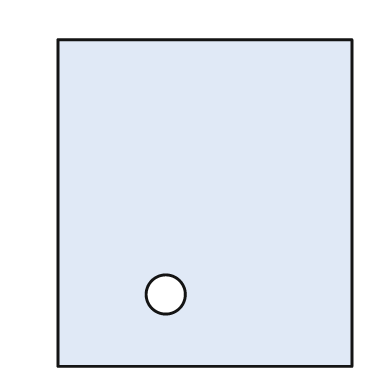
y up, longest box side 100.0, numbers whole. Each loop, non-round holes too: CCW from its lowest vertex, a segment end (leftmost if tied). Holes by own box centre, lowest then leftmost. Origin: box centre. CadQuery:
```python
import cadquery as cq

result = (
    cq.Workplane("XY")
    .moveTo(-45.0, -50.0)
    .lineTo(45.0, -50.0)
    .lineTo(45.0, 50.0)
    .lineTo(-45.0, 50.0)
    .close()
    .moveTo(-12.0, -28.0)
    .circle(6.0)
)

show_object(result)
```